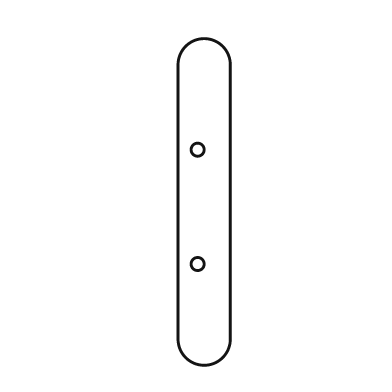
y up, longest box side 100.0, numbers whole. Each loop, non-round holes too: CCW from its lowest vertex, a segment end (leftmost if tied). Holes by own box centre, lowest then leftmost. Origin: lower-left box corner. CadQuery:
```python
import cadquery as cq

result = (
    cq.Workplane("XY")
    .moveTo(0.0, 8.0)
    .threePointArc((8.0, 0.0), (16.0, 8.0))
    .lineTo(16.0, 92.0)
    .threePointArc((8.0, 100.0), (0.0, 92.0))
    .close()
    .moveTo(6.0, 31.0)
    .circle(2.0)
    .moveTo(6.0, 66.0)
    .circle(2.0)
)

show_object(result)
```